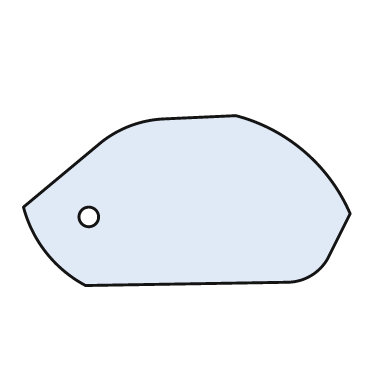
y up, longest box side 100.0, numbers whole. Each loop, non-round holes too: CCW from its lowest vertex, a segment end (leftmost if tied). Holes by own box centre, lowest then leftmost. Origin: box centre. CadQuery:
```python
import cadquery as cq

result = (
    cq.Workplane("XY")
    .moveTo(-31.0, -26.0)
    .lineTo(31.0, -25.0)
    .threePointArc((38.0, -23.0), (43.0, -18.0))
    .lineTo(50.0, -4.0)
    .threePointArc((36.0, 15.0), (15.0, 26.0))
    .lineTo(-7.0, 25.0)
    .threePointArc((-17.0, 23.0), (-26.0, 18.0))
    .lineTo(-50.0, -2.0)
    .threePointArc((-43.0, -16.0), (-31.0, -26.0))
    .close()
    .moveTo(-30.0, -5.0)
    .circle(3.0)
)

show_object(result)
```